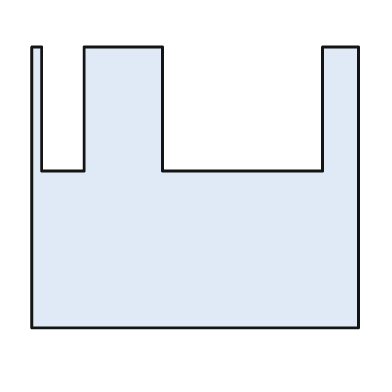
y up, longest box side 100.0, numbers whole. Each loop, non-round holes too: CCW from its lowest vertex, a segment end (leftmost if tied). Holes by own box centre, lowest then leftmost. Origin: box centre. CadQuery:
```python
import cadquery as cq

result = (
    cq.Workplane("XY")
    .moveTo(-50.0, -43.0)
    .lineTo(50.0, -43.0)
    .lineTo(50.0, 43.0)
    .lineTo(39.0, 43.0)
    .lineTo(39.0, 5.0)
    .lineTo(-10.0, 5.0)
    .lineTo(-10.0, 43.0)
    .lineTo(-34.0, 43.0)
    .lineTo(-34.0, 5.0)
    .lineTo(-47.0, 5.0)
    .lineTo(-47.0, 43.0)
    .lineTo(-50.0, 43.0)
    .close()
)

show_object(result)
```